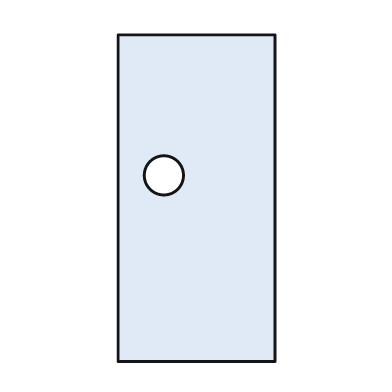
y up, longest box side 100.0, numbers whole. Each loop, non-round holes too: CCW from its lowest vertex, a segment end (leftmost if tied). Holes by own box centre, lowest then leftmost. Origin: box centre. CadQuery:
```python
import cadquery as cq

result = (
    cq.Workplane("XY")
    .moveTo(-24.0, -50.0)
    .lineTo(24.0, -50.0)
    .lineTo(24.0, 50.0)
    .lineTo(-24.0, 50.0)
    .close()
    .moveTo(-10.0, 7.0)
    .circle(6.0)
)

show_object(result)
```